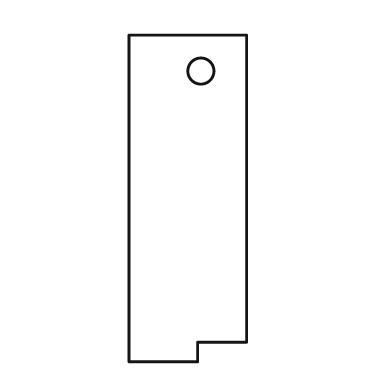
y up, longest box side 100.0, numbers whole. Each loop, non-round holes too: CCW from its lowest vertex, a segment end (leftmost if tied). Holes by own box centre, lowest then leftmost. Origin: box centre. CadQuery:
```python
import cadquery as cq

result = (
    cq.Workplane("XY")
    .moveTo(-18.0, -50.0)
    .lineTo(3.0, -50.0)
    .lineTo(3.0, -44.0)
    .lineTo(18.0, -44.0)
    .lineTo(18.0, 50.0)
    .lineTo(-18.0, 50.0)
    .close()
    .moveTo(4.0, 39.0)
    .circle(4.0)
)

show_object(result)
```